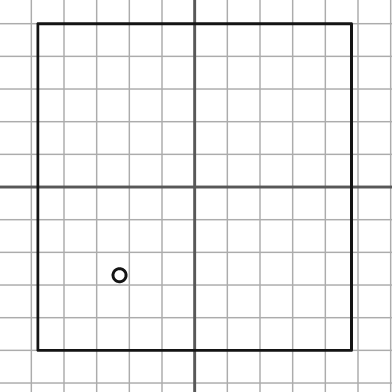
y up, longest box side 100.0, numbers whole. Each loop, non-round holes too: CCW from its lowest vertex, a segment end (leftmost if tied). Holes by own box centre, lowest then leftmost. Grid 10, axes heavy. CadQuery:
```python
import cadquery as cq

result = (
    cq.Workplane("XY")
    .moveTo(-48.0, -50.0)
    .lineTo(48.0, -50.0)
    .lineTo(48.0, 50.0)
    .lineTo(-48.0, 50.0)
    .close()
    .moveTo(-23.0, -27.0)
    .circle(2.0)
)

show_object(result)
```